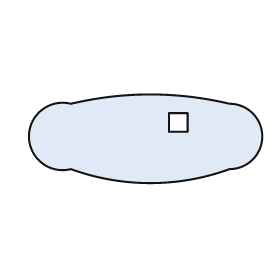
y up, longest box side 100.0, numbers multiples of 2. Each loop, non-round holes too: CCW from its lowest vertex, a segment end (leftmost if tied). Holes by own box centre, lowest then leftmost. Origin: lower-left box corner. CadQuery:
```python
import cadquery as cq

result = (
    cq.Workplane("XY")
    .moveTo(18.0, 6.0)
    .threePointArc((52.0, 0.0), (86.0, 6.0))
    .threePointArc((100.0, 20.0), (86.0, 34.0))
    .threePointArc((52.0, 38.0), (18.0, 34.0))
    .threePointArc((0.0, 20.0), (18.0, 6.0))
    .close()
    .moveTo(60.0, 22.0)
    .lineTo(68.0, 22.0)
    .lineTo(68.0, 30.0)
    .lineTo(60.0, 30.0)
    .close()
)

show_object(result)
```